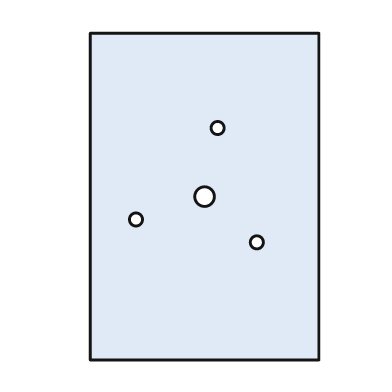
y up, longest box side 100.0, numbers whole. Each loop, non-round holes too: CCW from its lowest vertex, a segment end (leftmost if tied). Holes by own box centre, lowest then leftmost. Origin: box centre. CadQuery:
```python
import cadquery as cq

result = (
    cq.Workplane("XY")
    .moveTo(-35.0, -50.0)
    .lineTo(35.0, -50.0)
    .lineTo(35.0, 50.0)
    .lineTo(-35.0, 50.0)
    .close()
    .moveTo(16.0, -14.0)
    .circle(2.0)
    .moveTo(-21.0, -7.0)
    .circle(2.0)
    .moveTo(0.0, 0.0)
    .circle(3.0)
    .moveTo(4.0, 21.0)
    .circle(2.0)
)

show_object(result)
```